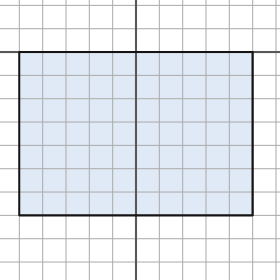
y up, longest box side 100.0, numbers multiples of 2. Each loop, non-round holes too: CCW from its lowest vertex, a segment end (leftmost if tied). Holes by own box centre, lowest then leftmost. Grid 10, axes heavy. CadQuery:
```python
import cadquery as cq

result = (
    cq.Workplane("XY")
    .moveTo(-50.0, -70.0)
    .lineTo(50.0, -70.0)
    .lineTo(50.0, 0.0)
    .lineTo(-50.0, 0.0)
    .close()
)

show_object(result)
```